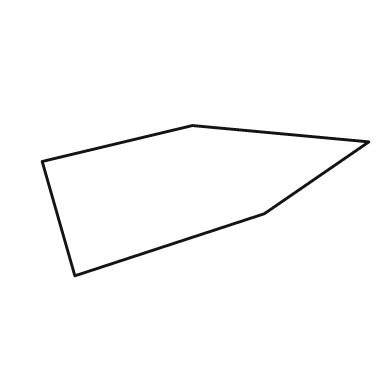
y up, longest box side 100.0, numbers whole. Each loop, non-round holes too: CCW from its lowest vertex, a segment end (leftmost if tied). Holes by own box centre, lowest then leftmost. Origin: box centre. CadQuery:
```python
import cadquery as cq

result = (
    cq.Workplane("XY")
    .moveTo(-40.0, -23.0)
    .lineTo(18.0, -4.0)
    .lineTo(50.0, 18.0)
    .lineTo(-4.0, 23.0)
    .lineTo(-50.0, 12.0)
    .close()
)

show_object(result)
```